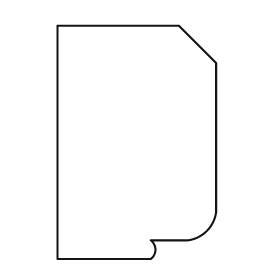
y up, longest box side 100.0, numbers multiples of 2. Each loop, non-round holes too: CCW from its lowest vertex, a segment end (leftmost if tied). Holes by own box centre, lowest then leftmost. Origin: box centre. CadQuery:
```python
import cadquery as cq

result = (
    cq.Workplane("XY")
    .moveTo(-34.0, -50.0)
    .lineTo(6.0, -50.0)
    .threePointArc((8.0, -46.0), (6.0, -42.0))
    .lineTo(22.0, -42.0)
    .threePointArc((30.0, -38.0), (34.0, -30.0))
    .lineTo(34.0, 34.0)
    .lineTo(18.0, 50.0)
    .lineTo(-34.0, 50.0)
    .close()
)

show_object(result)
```